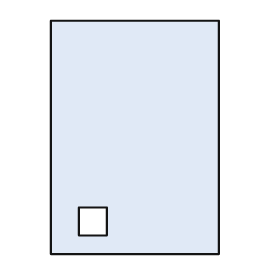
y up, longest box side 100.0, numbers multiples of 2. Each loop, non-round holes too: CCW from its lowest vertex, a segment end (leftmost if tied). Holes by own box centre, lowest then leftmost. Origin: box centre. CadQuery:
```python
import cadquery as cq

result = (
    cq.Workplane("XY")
    .moveTo(-36.0, -50.0)
    .lineTo(36.0, -50.0)
    .lineTo(36.0, 50.0)
    .lineTo(-36.0, 50.0)
    .close()
    .moveTo(-24.0, -42.0)
    .lineTo(-12.0, -42.0)
    .lineTo(-12.0, -30.0)
    .lineTo(-24.0, -30.0)
    .close()
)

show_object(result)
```